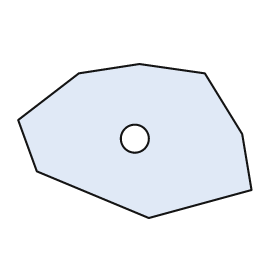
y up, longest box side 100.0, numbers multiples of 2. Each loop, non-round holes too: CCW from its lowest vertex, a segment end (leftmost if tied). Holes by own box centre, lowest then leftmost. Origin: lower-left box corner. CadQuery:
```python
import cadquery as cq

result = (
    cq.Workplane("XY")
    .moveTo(56.0, 0.0)
    .lineTo(100.0, 12.0)
    .lineTo(96.0, 36.0)
    .lineTo(80.0, 62.0)
    .lineTo(52.0, 66.0)
    .lineTo(26.0, 62.0)
    .lineTo(0.0, 42.0)
    .lineTo(8.0, 20.0)
    .close()
    .moveTo(50.0, 34.0)
    .circle(6.0)
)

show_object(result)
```